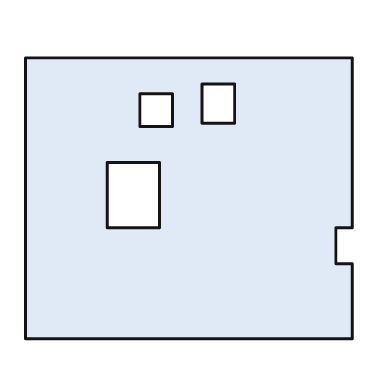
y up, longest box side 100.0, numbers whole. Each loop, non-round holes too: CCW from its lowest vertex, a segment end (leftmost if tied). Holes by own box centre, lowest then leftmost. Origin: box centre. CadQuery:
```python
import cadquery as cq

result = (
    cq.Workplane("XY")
    .moveTo(-50.0, -43.0)
    .lineTo(50.0, -43.0)
    .lineTo(50.0, -20.0)
    .lineTo(45.0, -20.0)
    .lineTo(45.0, -9.0)
    .lineTo(50.0, -9.0)
    .lineTo(50.0, 43.0)
    .lineTo(-50.0, 43.0)
    .close()
    .moveTo(-25.0, -9.0)
    .lineTo(-9.0, -9.0)
    .lineTo(-9.0, 11.0)
    .lineTo(-25.0, 11.0)
    .close()
    .moveTo(-15.0, 22.0)
    .lineTo(-5.0, 22.0)
    .lineTo(-5.0, 32.0)
    .lineTo(-15.0, 32.0)
    .close()
    .moveTo(4.0, 23.0)
    .lineTo(14.0, 23.0)
    .lineTo(14.0, 35.0)
    .lineTo(4.0, 35.0)
    .close()
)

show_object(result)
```